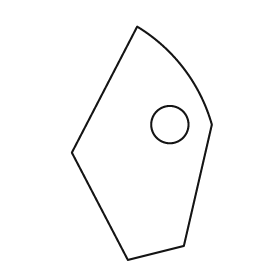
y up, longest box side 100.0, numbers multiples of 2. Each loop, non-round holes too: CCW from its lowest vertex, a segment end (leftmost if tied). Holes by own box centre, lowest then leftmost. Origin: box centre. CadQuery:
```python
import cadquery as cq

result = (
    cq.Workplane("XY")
    .moveTo(-6.0, -50.0)
    .lineTo(18.0, -44.0)
    .lineTo(30.0, 8.0)
    .threePointArc((18.0, 32.0), (-2.0, 50.0))
    .lineTo(-30.0, -4.0)
    .close()
    .moveTo(12.0, 8.0)
    .circle(8.0)
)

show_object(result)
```